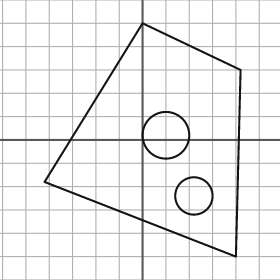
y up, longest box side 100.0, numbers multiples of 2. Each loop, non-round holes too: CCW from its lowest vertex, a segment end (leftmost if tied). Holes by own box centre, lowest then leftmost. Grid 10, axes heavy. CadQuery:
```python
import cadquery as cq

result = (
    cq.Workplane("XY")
    .moveTo(40.0, -50.0)
    .lineTo(42.0, 30.0)
    .lineTo(0.0, 50.0)
    .lineTo(-42.0, -18.0)
    .close()
    .moveTo(22.0, -24.0)
    .circle(8.0)
    .moveTo(10.0, 2.0)
    .circle(10.0)
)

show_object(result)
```